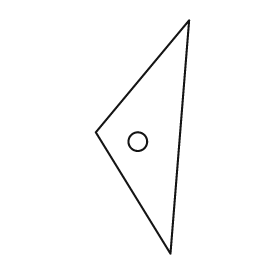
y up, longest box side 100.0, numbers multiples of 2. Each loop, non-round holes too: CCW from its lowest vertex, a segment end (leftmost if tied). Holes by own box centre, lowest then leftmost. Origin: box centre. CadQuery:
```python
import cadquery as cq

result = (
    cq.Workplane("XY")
    .moveTo(12.0, -50.0)
    .lineTo(20.0, 50.0)
    .lineTo(-20.0, 2.0)
    .close()
    .moveTo(-2.0, -2.0)
    .circle(4.0)
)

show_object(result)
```